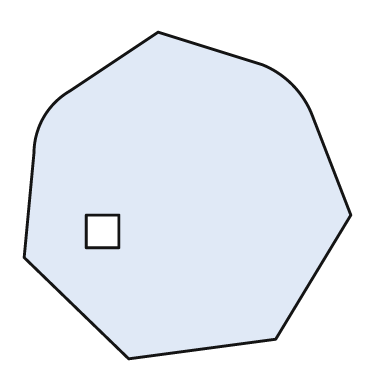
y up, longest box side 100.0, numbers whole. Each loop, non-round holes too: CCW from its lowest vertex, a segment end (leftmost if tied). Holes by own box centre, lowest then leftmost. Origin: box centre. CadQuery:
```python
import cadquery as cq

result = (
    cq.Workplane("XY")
    .moveTo(-18.0, -50.0)
    .lineTo(27.0, -44.0)
    .lineTo(50.0, -6.0)
    .lineTo(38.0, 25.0)
    .threePointArc((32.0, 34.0), (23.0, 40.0))
    .lineTo(-9.0, 50.0)
    .lineTo(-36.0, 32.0)
    .threePointArc((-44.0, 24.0), (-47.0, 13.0))
    .lineTo(-50.0, -19.0)
    .close()
    .moveTo(-31.0, -16.0)
    .lineTo(-21.0, -16.0)
    .lineTo(-21.0, -6.0)
    .lineTo(-31.0, -6.0)
    .close()
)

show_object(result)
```